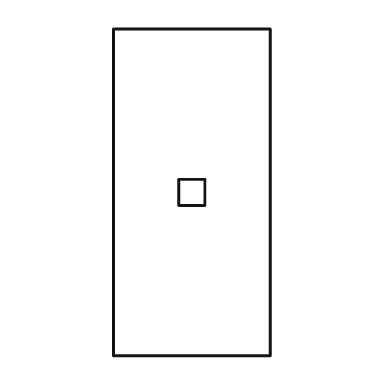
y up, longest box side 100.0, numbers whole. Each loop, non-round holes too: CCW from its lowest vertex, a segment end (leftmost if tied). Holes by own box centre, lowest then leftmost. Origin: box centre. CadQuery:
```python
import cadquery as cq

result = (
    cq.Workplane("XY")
    .moveTo(-24.0, -50.0)
    .lineTo(24.0, -50.0)
    .lineTo(24.0, 50.0)
    .lineTo(-24.0, 50.0)
    .close()
    .moveTo(-4.0, -4.0)
    .lineTo(4.0, -4.0)
    .lineTo(4.0, 4.0)
    .lineTo(-4.0, 4.0)
    .close()
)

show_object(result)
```